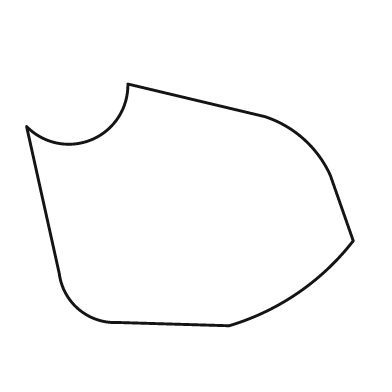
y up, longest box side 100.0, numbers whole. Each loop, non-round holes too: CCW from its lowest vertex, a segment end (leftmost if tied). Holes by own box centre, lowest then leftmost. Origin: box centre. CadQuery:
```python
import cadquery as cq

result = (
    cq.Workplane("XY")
    .moveTo(12.0, -37.0)
    .threePointArc((33.0, -27.0), (50.0, -11.0))
    .lineTo(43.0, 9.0)
    .threePointArc((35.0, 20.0), (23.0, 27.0))
    .lineTo(-19.0, 37.0)
    .threePointArc((-30.0, 20.0), (-50.0, 24.0))
    .lineTo(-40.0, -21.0)
    .threePointArc((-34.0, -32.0), (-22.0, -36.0))
    .close()
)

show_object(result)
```